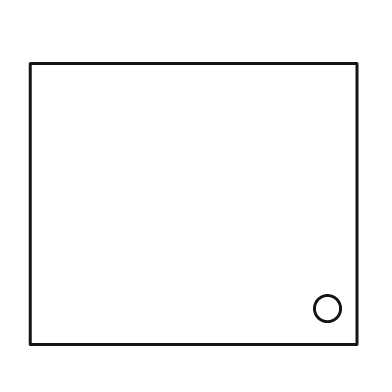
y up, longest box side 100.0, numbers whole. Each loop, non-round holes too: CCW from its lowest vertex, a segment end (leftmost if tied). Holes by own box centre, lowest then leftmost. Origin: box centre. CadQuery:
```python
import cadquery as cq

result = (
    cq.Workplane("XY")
    .moveTo(-50.0, -43.0)
    .lineTo(50.0, -43.0)
    .lineTo(50.0, 43.0)
    .lineTo(-50.0, 43.0)
    .close()
    .moveTo(41.0, -32.0)
    .circle(4.0)
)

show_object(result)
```